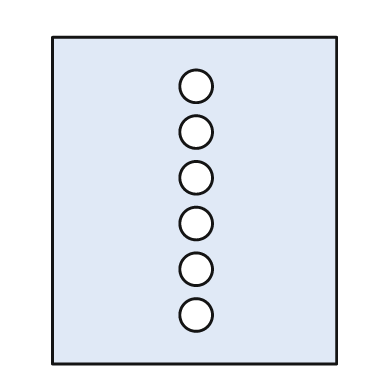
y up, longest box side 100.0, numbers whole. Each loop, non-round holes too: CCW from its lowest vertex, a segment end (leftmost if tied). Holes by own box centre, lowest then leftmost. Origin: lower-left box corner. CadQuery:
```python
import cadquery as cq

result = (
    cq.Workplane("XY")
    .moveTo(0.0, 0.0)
    .lineTo(87.0, 0.0)
    .lineTo(87.0, 100.0)
    .lineTo(0.0, 100.0)
    .close()
    .moveTo(44.0, 15.0)
    .circle(5.0)
    .moveTo(44.0, 29.0)
    .circle(5.0)
    .moveTo(44.0, 43.0)
    .circle(5.0)
    .moveTo(44.0, 57.0)
    .circle(5.0)
    .moveTo(44.0, 71.0)
    .circle(5.0)
    .moveTo(44.0, 85.0)
    .circle(5.0)
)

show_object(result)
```